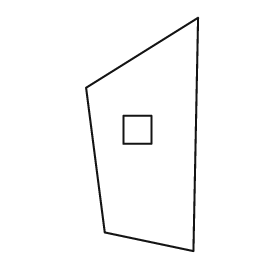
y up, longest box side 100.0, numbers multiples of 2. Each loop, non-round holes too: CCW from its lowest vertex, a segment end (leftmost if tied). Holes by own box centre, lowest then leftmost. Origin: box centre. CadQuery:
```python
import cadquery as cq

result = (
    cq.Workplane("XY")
    .moveTo(22.0, -50.0)
    .lineTo(24.0, 50.0)
    .lineTo(-24.0, 20.0)
    .lineTo(-16.0, -42.0)
    .close()
    .moveTo(-8.0, -4.0)
    .lineTo(4.0, -4.0)
    .lineTo(4.0, 8.0)
    .lineTo(-8.0, 8.0)
    .close()
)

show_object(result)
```